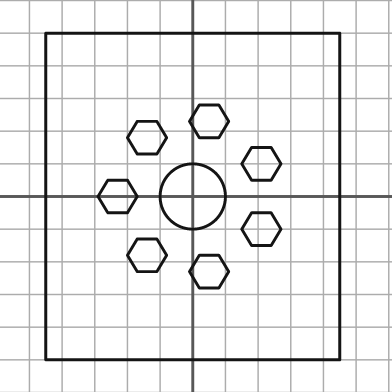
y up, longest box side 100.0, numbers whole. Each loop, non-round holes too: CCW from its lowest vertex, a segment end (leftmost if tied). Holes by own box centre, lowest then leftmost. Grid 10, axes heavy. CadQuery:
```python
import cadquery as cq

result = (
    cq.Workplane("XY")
    .moveTo(-45.0, -50.0)
    .lineTo(45.0, -50.0)
    .lineTo(45.0, 50.0)
    .lineTo(-45.0, 50.0)
    .close()
    .moveTo(2.0, -28.0)
    .lineTo(8.0, -28.0)
    .lineTo(11.0, -23.0)
    .lineTo(8.0, -18.0)
    .lineTo(2.0, -18.0)
    .lineTo(-1.0, -23.0)
    .close()
    .moveTo(-17.0, -23.0)
    .lineTo(-11.0, -23.0)
    .lineTo(-8.0, -18.0)
    .lineTo(-11.0, -13.0)
    .lineTo(-17.0, -13.0)
    .lineTo(-20.0, -18.0)
    .close()
    .moveTo(18.0, -15.0)
    .lineTo(24.0, -15.0)
    .lineTo(27.0, -10.0)
    .lineTo(24.0, -5.0)
    .lineTo(18.0, -5.0)
    .lineTo(15.0, -10.0)
    .close()
    .moveTo(-26.0, -5.0)
    .lineTo(-20.0, -5.0)
    .lineTo(-17.0, 0.0)
    .lineTo(-20.0, 5.0)
    .lineTo(-26.0, 5.0)
    .lineTo(-29.0, 0.0)
    .close()
    .moveTo(0.0, 0.0)
    .circle(10.0)
    .moveTo(18.0, 5.0)
    .lineTo(24.0, 5.0)
    .lineTo(27.0, 10.0)
    .lineTo(24.0, 15.0)
    .lineTo(18.0, 15.0)
    .lineTo(15.0, 10.0)
    .close()
    .moveTo(-17.0, 13.0)
    .lineTo(-11.0, 13.0)
    .lineTo(-8.0, 18.0)
    .lineTo(-11.0, 23.0)
    .lineTo(-17.0, 23.0)
    .lineTo(-20.0, 18.0)
    .close()
    .moveTo(2.0, 18.0)
    .lineTo(8.0, 18.0)
    .lineTo(11.0, 23.0)
    .lineTo(8.0, 28.0)
    .lineTo(2.0, 28.0)
    .lineTo(-1.0, 23.0)
    .close()
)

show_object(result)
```